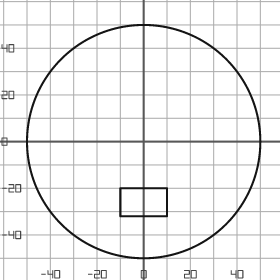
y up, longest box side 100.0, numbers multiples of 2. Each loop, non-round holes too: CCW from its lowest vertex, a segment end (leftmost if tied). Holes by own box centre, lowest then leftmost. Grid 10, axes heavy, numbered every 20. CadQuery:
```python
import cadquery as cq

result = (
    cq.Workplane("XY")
    .moveTo(0.0, 0.0)
    .circle(50.0)
    .moveTo(-10.0, -32.0)
    .lineTo(10.0, -32.0)
    .lineTo(10.0, -20.0)
    .lineTo(-10.0, -20.0)
    .close()
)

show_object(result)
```